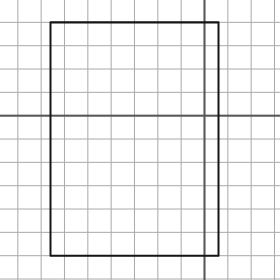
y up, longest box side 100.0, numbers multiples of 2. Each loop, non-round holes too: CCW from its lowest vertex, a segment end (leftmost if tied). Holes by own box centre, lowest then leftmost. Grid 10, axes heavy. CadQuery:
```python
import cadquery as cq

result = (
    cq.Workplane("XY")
    .moveTo(-66.0, -60.0)
    .lineTo(6.0, -60.0)
    .lineTo(6.0, 40.0)
    .lineTo(-66.0, 40.0)
    .close()
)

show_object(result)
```